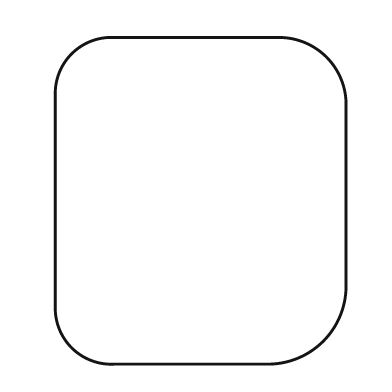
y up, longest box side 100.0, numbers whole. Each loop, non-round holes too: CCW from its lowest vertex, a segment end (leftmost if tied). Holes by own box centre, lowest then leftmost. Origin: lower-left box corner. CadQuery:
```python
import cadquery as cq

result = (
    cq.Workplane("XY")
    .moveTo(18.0, 0.0)
    .lineTo(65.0, 0.0)
    .threePointArc((82.0, 7.0), (89.0, 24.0))
    .lineTo(89.0, 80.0)
    .threePointArc((83.0, 94.0), (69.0, 100.0))
    .lineTo(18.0, 100.0)
    .threePointArc((5.0, 95.0), (0.0, 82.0))
    .lineTo(0.0, 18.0)
    .threePointArc((5.0, 5.0), (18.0, 0.0))
    .close()
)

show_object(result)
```